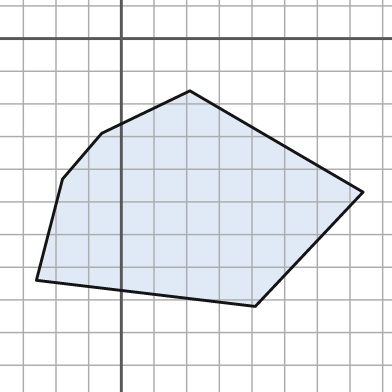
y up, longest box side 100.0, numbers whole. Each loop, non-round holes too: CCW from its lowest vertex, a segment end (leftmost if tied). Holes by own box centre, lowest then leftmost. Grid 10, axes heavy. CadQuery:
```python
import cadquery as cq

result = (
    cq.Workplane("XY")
    .moveTo(41.0, -82.0)
    .lineTo(74.0, -47.0)
    .lineTo(21.0, -16.0)
    .lineTo(-6.0, -29.0)
    .lineTo(-18.0, -43.0)
    .lineTo(-26.0, -74.0)
    .close()
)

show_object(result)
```